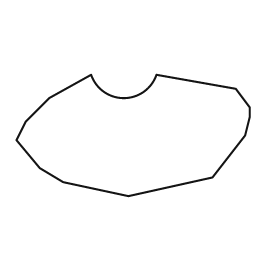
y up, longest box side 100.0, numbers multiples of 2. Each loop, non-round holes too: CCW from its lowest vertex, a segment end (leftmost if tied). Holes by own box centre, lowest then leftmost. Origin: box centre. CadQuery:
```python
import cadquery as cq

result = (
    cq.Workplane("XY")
    .moveTo(-2.0, -26.0)
    .lineTo(34.0, -18.0)
    .lineTo(48.0, 0.0)
    .lineTo(50.0, 8.0)
    .lineTo(50.0, 12.0)
    .lineTo(44.0, 20.0)
    .lineTo(10.0, 26.0)
    .threePointArc((-4.0, 16.0), (-18.0, 26.0))
    .lineTo(-36.0, 16.0)
    .lineTo(-46.0, 6.0)
    .lineTo(-50.0, -2.0)
    .lineTo(-40.0, -14.0)
    .lineTo(-30.0, -20.0)
    .close()
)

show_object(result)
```